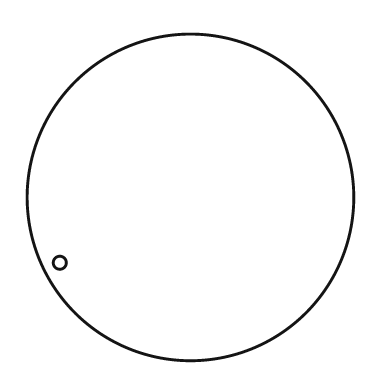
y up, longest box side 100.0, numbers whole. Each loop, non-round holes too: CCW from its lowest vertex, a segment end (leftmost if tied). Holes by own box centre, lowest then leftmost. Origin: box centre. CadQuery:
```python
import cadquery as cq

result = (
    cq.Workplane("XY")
    .moveTo(0.0, 0.0)
    .circle(50.0)
    .moveTo(-40.0, -20.0)
    .circle(2.0)
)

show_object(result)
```